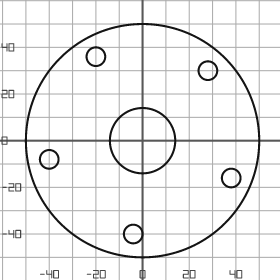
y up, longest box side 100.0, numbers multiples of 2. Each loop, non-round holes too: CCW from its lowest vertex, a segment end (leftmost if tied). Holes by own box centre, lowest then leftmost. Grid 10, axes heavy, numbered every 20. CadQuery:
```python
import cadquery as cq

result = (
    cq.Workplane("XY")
    .moveTo(0.0, 0.0)
    .circle(50.0)
    .moveTo(-4.0, -40.0)
    .circle(4.0)
    .moveTo(38.0, -16.0)
    .circle(4.0)
    .moveTo(-40.0, -8.0)
    .circle(4.0)
    .moveTo(0.0, 0.0)
    .circle(14.0)
    .moveTo(28.0, 30.0)
    .circle(4.0)
    .moveTo(-20.0, 36.0)
    .circle(4.0)
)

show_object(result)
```